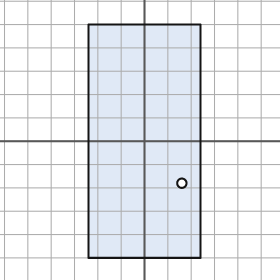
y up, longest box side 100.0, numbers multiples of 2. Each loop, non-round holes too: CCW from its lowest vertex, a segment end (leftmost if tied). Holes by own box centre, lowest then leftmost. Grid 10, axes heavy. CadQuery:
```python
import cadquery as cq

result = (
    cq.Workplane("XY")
    .moveTo(-24.0, -50.0)
    .lineTo(24.0, -50.0)
    .lineTo(24.0, 50.0)
    .lineTo(-24.0, 50.0)
    .close()
    .moveTo(16.0, -18.0)
    .circle(2.0)
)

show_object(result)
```